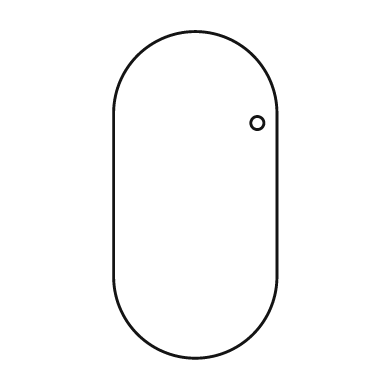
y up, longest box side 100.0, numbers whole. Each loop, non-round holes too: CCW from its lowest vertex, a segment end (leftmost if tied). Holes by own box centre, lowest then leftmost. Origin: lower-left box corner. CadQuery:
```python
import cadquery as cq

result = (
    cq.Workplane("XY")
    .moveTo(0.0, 25.0)
    .threePointArc((25.0, 0.0), (50.0, 25.0))
    .lineTo(50.0, 75.0)
    .threePointArc((25.0, 100.0), (0.0, 75.0))
    .close()
    .moveTo(44.0, 72.0)
    .circle(2.0)
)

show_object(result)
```